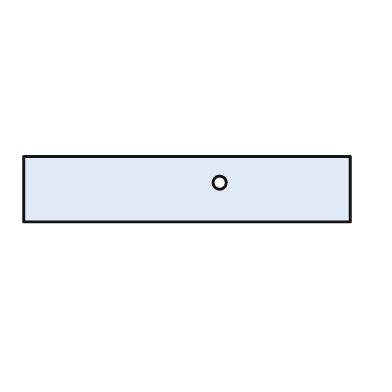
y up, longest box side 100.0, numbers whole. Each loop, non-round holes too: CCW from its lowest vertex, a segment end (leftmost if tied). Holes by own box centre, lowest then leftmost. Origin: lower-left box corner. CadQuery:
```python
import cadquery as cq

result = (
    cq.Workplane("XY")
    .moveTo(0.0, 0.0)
    .lineTo(100.0, 0.0)
    .lineTo(100.0, 20.0)
    .lineTo(0.0, 20.0)
    .close()
    .moveTo(60.0, 12.0)
    .circle(2.0)
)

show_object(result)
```